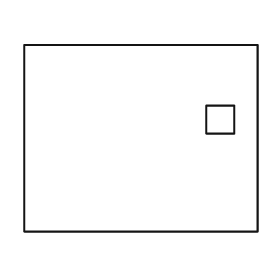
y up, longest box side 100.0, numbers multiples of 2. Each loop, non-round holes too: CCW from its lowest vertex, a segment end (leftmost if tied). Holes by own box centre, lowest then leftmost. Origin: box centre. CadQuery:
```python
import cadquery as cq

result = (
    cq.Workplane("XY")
    .moveTo(-50.0, -40.0)
    .lineTo(50.0, -40.0)
    .lineTo(50.0, 40.0)
    .lineTo(-50.0, 40.0)
    .close()
    .moveTo(28.0, 2.0)
    .lineTo(40.0, 2.0)
    .lineTo(40.0, 14.0)
    .lineTo(28.0, 14.0)
    .close()
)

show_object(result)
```